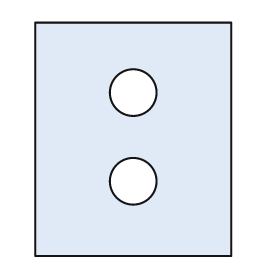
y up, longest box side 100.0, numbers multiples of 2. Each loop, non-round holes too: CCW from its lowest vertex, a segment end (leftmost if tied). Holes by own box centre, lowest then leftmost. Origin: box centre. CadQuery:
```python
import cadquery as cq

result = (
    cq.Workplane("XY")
    .moveTo(-42.0, -50.0)
    .lineTo(42.0, -50.0)
    .lineTo(42.0, 50.0)
    .lineTo(-42.0, 50.0)
    .close()
    .moveTo(0.0, -18.0)
    .circle(10.0)
    .moveTo(0.0, 20.0)
    .circle(10.0)
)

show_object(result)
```